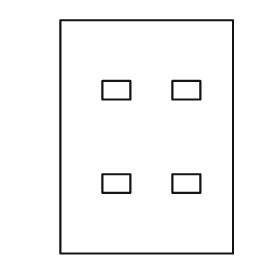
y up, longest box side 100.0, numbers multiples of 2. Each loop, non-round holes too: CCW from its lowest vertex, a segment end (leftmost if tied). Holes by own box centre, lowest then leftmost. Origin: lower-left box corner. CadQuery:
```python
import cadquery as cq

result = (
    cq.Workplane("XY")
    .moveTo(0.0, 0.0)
    .lineTo(74.0, 0.0)
    .lineTo(74.0, 100.0)
    .lineTo(0.0, 100.0)
    .close()
    .moveTo(18.0, 26.0)
    .lineTo(30.0, 26.0)
    .lineTo(30.0, 34.0)
    .lineTo(18.0, 34.0)
    .close()
    .moveTo(48.0, 26.0)
    .lineTo(60.0, 26.0)
    .lineTo(60.0, 34.0)
    .lineTo(48.0, 34.0)
    .close()
    .moveTo(18.0, 66.0)
    .lineTo(30.0, 66.0)
    .lineTo(30.0, 74.0)
    .lineTo(18.0, 74.0)
    .close()
    .moveTo(48.0, 66.0)
    .lineTo(60.0, 66.0)
    .lineTo(60.0, 74.0)
    .lineTo(48.0, 74.0)
    .close()
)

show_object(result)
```